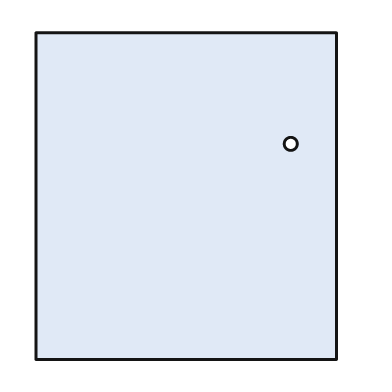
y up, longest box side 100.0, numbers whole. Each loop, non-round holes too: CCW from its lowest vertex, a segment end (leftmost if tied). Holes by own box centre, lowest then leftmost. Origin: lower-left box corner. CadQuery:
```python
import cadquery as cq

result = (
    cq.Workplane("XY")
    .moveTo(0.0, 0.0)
    .lineTo(92.0, 0.0)
    .lineTo(92.0, 100.0)
    .lineTo(0.0, 100.0)
    .close()
    .moveTo(78.0, 66.0)
    .circle(2.0)
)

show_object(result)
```